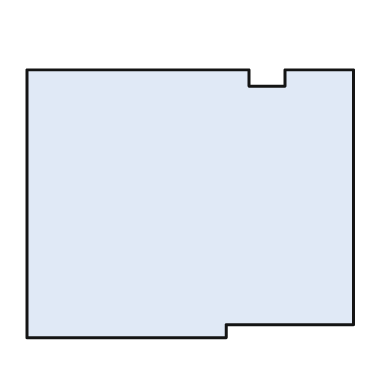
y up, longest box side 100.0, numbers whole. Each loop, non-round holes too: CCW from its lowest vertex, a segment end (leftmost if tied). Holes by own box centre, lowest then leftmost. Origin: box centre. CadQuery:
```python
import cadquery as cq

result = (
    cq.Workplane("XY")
    .moveTo(-50.0, -41.0)
    .lineTo(11.0, -41.0)
    .lineTo(11.0, -37.0)
    .lineTo(50.0, -37.0)
    .lineTo(50.0, 41.0)
    .lineTo(29.0, 41.0)
    .lineTo(29.0, 36.0)
    .lineTo(18.0, 36.0)
    .lineTo(18.0, 41.0)
    .lineTo(-50.0, 41.0)
    .close()
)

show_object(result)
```